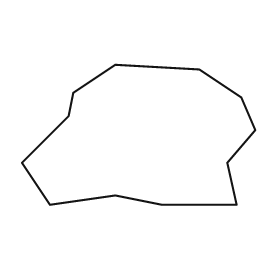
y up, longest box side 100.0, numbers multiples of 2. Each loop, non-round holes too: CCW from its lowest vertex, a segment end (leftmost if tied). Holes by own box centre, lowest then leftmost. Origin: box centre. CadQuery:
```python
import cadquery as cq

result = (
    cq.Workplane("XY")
    .moveTo(-38.0, -30.0)
    .lineTo(-10.0, -26.0)
    .lineTo(10.0, -30.0)
    .lineTo(42.0, -30.0)
    .lineTo(38.0, -12.0)
    .lineTo(50.0, 2.0)
    .lineTo(44.0, 16.0)
    .lineTo(26.0, 28.0)
    .lineTo(-10.0, 30.0)
    .lineTo(-28.0, 18.0)
    .lineTo(-30.0, 8.0)
    .lineTo(-50.0, -12.0)
    .close()
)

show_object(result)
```